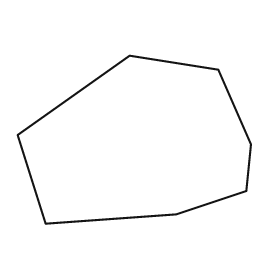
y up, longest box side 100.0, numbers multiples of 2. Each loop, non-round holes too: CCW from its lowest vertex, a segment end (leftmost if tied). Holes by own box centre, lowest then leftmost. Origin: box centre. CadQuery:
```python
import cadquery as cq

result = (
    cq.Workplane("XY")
    .moveTo(-38.0, -36.0)
    .lineTo(18.0, -32.0)
    .lineTo(48.0, -22.0)
    .lineTo(50.0, -2.0)
    .lineTo(36.0, 30.0)
    .lineTo(-2.0, 36.0)
    .lineTo(-50.0, 2.0)
    .close()
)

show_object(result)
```